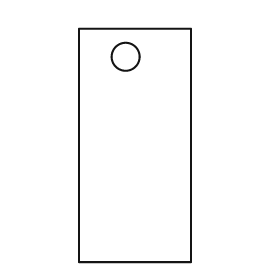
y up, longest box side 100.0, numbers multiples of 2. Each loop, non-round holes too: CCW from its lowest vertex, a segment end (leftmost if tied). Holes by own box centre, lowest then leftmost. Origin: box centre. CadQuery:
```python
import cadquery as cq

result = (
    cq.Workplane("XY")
    .moveTo(-24.0, -50.0)
    .lineTo(24.0, -50.0)
    .lineTo(24.0, 50.0)
    .lineTo(-24.0, 50.0)
    .close()
    .moveTo(-4.0, 38.0)
    .circle(6.0)
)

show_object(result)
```